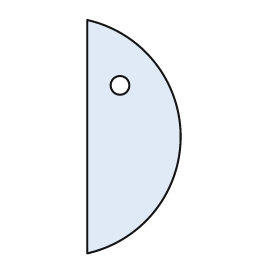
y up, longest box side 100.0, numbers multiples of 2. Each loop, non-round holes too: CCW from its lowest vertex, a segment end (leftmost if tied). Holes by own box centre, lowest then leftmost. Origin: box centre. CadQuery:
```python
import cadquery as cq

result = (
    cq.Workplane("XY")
    .moveTo(-20.0, -50.0)
    .threePointArc((20.0, 0.0), (-20.0, 50.0))
    .close()
    .moveTo(-6.0, 22.0)
    .circle(4.0)
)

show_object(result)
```